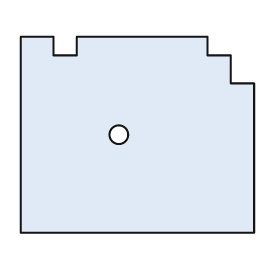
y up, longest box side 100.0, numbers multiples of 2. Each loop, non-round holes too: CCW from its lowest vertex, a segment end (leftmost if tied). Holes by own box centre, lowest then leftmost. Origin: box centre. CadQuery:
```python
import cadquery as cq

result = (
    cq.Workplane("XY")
    .moveTo(-50.0, -42.0)
    .lineTo(50.0, -42.0)
    .lineTo(50.0, 22.0)
    .lineTo(40.0, 22.0)
    .lineTo(40.0, 34.0)
    .lineTo(30.0, 34.0)
    .lineTo(30.0, 42.0)
    .lineTo(-26.0, 42.0)
    .lineTo(-26.0, 34.0)
    .lineTo(-36.0, 34.0)
    .lineTo(-36.0, 42.0)
    .lineTo(-50.0, 42.0)
    .close()
    .moveTo(-8.0, 0.0)
    .circle(4.0)
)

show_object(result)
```